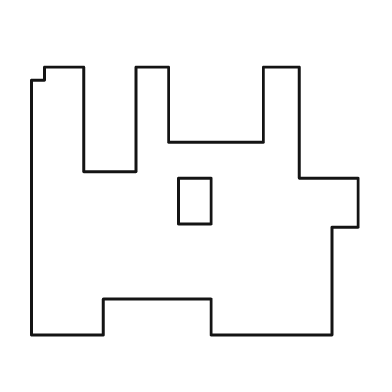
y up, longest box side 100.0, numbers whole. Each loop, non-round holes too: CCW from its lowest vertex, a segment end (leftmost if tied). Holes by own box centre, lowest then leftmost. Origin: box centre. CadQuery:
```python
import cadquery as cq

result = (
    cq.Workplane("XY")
    .moveTo(-50.0, -41.0)
    .lineTo(-28.0, -41.0)
    .lineTo(-28.0, -30.0)
    .lineTo(5.0, -30.0)
    .lineTo(5.0, -41.0)
    .lineTo(42.0, -41.0)
    .lineTo(42.0, -8.0)
    .lineTo(50.0, -8.0)
    .lineTo(50.0, 7.0)
    .lineTo(32.0, 7.0)
    .lineTo(32.0, 41.0)
    .lineTo(21.0, 41.0)
    .lineTo(21.0, 18.0)
    .lineTo(-8.0, 18.0)
    .lineTo(-8.0, 41.0)
    .lineTo(-18.0, 41.0)
    .lineTo(-18.0, 9.0)
    .lineTo(-34.0, 9.0)
    .lineTo(-34.0, 41.0)
    .lineTo(-46.0, 41.0)
    .lineTo(-46.0, 37.0)
    .lineTo(-50.0, 37.0)
    .close()
    .moveTo(-5.0, -7.0)
    .lineTo(5.0, -7.0)
    .lineTo(5.0, 7.0)
    .lineTo(-5.0, 7.0)
    .close()
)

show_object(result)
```